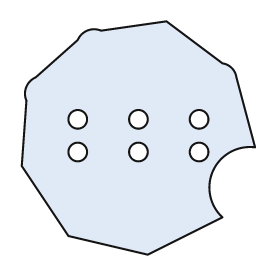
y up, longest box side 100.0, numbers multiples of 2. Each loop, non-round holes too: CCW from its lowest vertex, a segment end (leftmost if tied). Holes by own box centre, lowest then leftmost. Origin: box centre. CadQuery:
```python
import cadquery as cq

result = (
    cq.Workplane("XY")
    .moveTo(4.0, -50.0)
    .lineTo(36.0, -34.0)
    .threePointArc((32.0, -14.0), (50.0, -4.0))
    .lineTo(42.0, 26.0)
    .threePointArc((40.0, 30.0), (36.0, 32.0))
    .lineTo(12.0, 50.0)
    .lineTo(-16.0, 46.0)
    .threePointArc((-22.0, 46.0), (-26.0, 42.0))
    .lineTo(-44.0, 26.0)
    .threePointArc((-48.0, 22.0), (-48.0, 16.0))
    .lineTo(-50.0, -12.0)
    .lineTo(-30.0, -42.0)
    .close()
    .moveTo(-26.0, -6.0)
    .circle(4.0)
    .moveTo(0.0, -6.0)
    .circle(4.0)
    .moveTo(26.0, -6.0)
    .circle(4.0)
    .moveTo(-26.0, 8.0)
    .circle(4.0)
    .moveTo(0.0, 8.0)
    .circle(4.0)
    .moveTo(26.0, 8.0)
    .circle(4.0)
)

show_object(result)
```